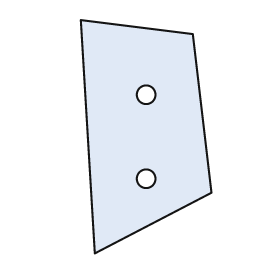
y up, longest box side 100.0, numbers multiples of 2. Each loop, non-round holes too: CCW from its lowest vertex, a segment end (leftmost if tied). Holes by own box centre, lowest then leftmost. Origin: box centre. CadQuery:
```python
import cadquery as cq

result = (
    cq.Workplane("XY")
    .moveTo(-22.0, -50.0)
    .lineTo(28.0, -24.0)
    .lineTo(20.0, 44.0)
    .lineTo(-28.0, 50.0)
    .close()
    .moveTo(0.0, -18.0)
    .circle(4.0)
    .moveTo(0.0, 18.0)
    .circle(4.0)
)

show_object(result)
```